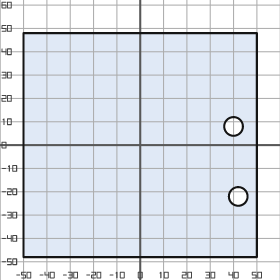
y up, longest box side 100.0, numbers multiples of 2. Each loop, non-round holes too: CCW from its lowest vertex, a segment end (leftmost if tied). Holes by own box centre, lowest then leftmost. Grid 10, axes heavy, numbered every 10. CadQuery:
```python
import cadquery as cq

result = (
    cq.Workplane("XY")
    .moveTo(-50.0, -48.0)
    .lineTo(50.0, -48.0)
    .lineTo(50.0, 48.0)
    .lineTo(-50.0, 48.0)
    .close()
    .moveTo(42.0, -22.0)
    .circle(4.0)
    .moveTo(40.0, 8.0)
    .circle(4.0)
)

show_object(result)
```